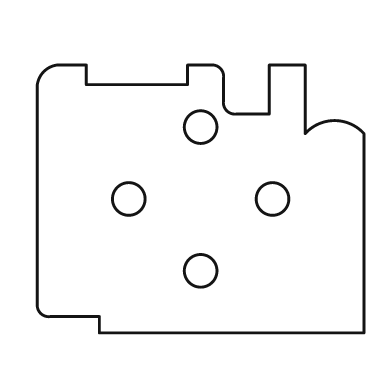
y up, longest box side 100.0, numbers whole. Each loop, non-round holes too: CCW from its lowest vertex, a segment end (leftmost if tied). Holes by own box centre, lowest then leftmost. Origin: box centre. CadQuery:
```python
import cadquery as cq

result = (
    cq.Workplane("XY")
    .moveTo(-31.0, -41.0)
    .lineTo(50.0, -41.0)
    .lineTo(50.0, 20.0)
    .threePointArc((41.0, 24.0), (32.0, 20.0))
    .lineTo(32.0, 41.0)
    .lineTo(21.0, 41.0)
    .lineTo(21.0, 26.0)
    .lineTo(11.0, 26.0)
    .threePointArc((8.0, 27.0), (7.0, 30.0))
    .lineTo(7.0, 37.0)
    .threePointArc((6.0, 40.0), (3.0, 41.0))
    .lineTo(-4.0, 41.0)
    .lineTo(-4.0, 35.0)
    .lineTo(-35.0, 35.0)
    .lineTo(-35.0, 41.0)
    .lineTo(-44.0, 41.0)
    .threePointArc((-48.0, 39.0), (-50.0, 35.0))
    .lineTo(-50.0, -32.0)
    .threePointArc((-49.0, -35.0), (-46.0, -36.0))
    .lineTo(-31.0, -36.0)
    .close()
    .moveTo(0.0, -22.0)
    .circle(5.0)
    .moveTo(-22.0, 0.0)
    .circle(5.0)
    .moveTo(22.0, 0.0)
    .circle(5.0)
    .moveTo(0.0, 22.0)
    .circle(5.0)
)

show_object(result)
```